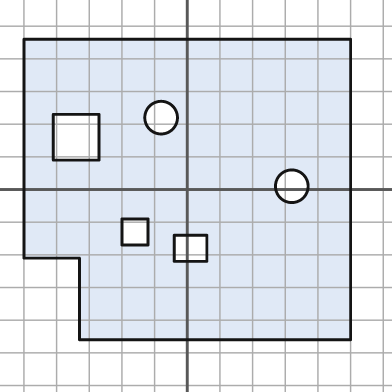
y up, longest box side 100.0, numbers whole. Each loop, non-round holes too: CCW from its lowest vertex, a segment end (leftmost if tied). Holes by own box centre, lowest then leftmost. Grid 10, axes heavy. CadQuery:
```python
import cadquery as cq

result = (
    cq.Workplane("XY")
    .moveTo(-33.0, -46.0)
    .lineTo(50.0, -46.0)
    .lineTo(50.0, 46.0)
    .lineTo(-50.0, 46.0)
    .lineTo(-50.0, -21.0)
    .lineTo(-33.0, -21.0)
    .close()
    .moveTo(-4.0, -22.0)
    .lineTo(6.0, -22.0)
    .lineTo(6.0, -14.0)
    .lineTo(-4.0, -14.0)
    .close()
    .moveTo(-20.0, -17.0)
    .lineTo(-12.0, -17.0)
    .lineTo(-12.0, -9.0)
    .lineTo(-20.0, -9.0)
    .close()
    .moveTo(32.0, 1.0)
    .circle(5.0)
    .moveTo(-41.0, 9.0)
    .lineTo(-27.0, 9.0)
    .lineTo(-27.0, 23.0)
    .lineTo(-41.0, 23.0)
    .close()
    .moveTo(-8.0, 22.0)
    .circle(5.0)
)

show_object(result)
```